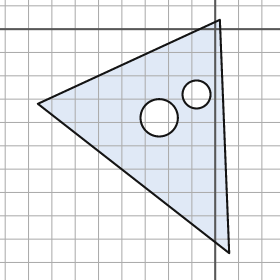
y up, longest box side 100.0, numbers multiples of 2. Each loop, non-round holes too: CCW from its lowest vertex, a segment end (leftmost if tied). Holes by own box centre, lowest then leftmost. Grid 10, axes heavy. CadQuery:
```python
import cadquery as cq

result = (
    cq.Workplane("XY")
    .moveTo(6.0, -96.0)
    .lineTo(2.0, 4.0)
    .lineTo(-76.0, -32.0)
    .close()
    .moveTo(-24.0, -38.0)
    .circle(8.0)
    .moveTo(-8.0, -28.0)
    .circle(6.0)
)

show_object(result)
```